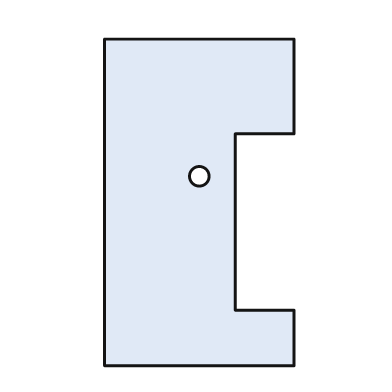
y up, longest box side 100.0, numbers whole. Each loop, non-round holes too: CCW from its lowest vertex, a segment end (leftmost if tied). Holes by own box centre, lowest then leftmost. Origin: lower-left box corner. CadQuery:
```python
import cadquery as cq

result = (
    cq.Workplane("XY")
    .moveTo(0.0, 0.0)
    .lineTo(58.0, 0.0)
    .lineTo(58.0, 17.0)
    .lineTo(40.0, 17.0)
    .lineTo(40.0, 71.0)
    .lineTo(58.0, 71.0)
    .lineTo(58.0, 100.0)
    .lineTo(0.0, 100.0)
    .close()
    .moveTo(29.0, 58.0)
    .circle(3.0)
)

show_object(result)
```